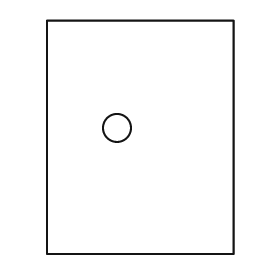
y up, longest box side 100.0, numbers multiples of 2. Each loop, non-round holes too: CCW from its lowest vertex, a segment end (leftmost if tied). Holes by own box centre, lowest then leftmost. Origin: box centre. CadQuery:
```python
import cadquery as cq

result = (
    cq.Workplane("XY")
    .moveTo(-40.0, -50.0)
    .lineTo(40.0, -50.0)
    .lineTo(40.0, 50.0)
    .lineTo(-40.0, 50.0)
    .close()
    .moveTo(-10.0, 4.0)
    .circle(6.0)
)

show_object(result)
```